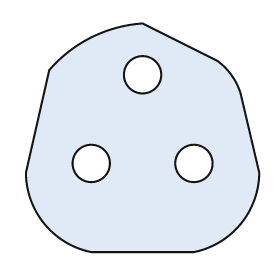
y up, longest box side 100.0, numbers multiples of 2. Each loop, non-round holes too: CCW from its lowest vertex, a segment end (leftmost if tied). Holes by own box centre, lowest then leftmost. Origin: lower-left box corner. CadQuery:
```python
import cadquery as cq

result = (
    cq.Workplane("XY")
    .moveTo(28.0, 0.0)
    .lineTo(72.0, 0.0)
    .threePointArc((92.0, 12.0), (100.0, 34.0))
    .lineTo(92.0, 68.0)
    .threePointArc((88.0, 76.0), (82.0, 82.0))
    .lineTo(50.0, 98.0)
    .threePointArc((28.0, 92.0), (10.0, 78.0))
    .lineTo(0.0, 34.0)
    .threePointArc((8.0, 12.0), (28.0, 0.0))
    .close()
    .moveTo(28.0, 38.0)
    .circle(8.0)
    .moveTo(72.0, 38.0)
    .circle(8.0)
    .moveTo(50.0, 76.0)
    .circle(8.0)
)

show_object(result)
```